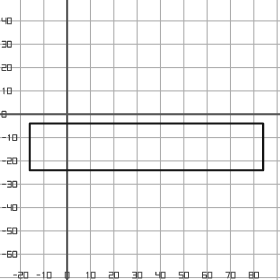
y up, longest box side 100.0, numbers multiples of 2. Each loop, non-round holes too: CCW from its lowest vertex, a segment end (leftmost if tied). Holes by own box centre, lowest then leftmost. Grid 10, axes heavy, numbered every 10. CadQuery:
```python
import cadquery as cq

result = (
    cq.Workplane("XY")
    .moveTo(-16.0, -24.0)
    .lineTo(84.0, -24.0)
    .lineTo(84.0, -4.0)
    .lineTo(-16.0, -4.0)
    .close()
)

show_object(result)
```